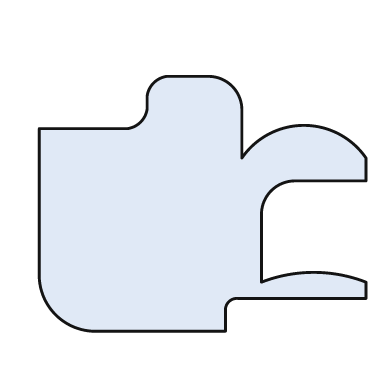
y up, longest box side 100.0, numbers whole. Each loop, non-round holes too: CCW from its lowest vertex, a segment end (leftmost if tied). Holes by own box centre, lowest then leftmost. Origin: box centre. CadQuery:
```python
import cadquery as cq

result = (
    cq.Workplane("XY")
    .moveTo(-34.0, -39.0)
    .lineTo(7.0, -39.0)
    .lineTo(7.0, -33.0)
    .threePointArc((8.0, -30.0), (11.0, -29.0))
    .lineTo(50.0, -29.0)
    .lineTo(50.0, -24.0)
    .threePointArc((34.0, -21.0), (18.0, -24.0))
    .lineTo(18.0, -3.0)
    .threePointArc((21.0, 4.0), (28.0, 7.0))
    .lineTo(50.0, 7.0)
    .lineTo(50.0, 14.0)
    .threePointArc((31.0, 24.0), (12.0, 14.0))
    .lineTo(12.0, 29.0)
    .threePointArc((9.0, 36.0), (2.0, 39.0))
    .lineTo(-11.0, 39.0)
    .threePointArc((-15.0, 37.0), (-17.0, 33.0))
    .lineTo(-17.0, 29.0)
    .threePointArc((-19.0, 25.0), (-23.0, 23.0))
    .lineTo(-50.0, 23.0)
    .lineTo(-50.0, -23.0)
    .threePointArc((-45.0, -34.0), (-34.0, -39.0))
    .close()
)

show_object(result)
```